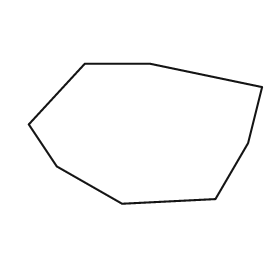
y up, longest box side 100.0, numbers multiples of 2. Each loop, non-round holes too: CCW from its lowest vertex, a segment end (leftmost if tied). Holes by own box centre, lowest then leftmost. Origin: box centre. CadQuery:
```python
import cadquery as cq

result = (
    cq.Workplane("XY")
    .moveTo(-10.0, -30.0)
    .lineTo(30.0, -28.0)
    .lineTo(44.0, -4.0)
    .lineTo(50.0, 20.0)
    .lineTo(2.0, 30.0)
    .lineTo(-26.0, 30.0)
    .lineTo(-50.0, 4.0)
    .lineTo(-38.0, -14.0)
    .close()
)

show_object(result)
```